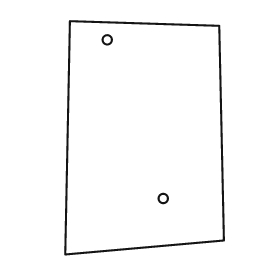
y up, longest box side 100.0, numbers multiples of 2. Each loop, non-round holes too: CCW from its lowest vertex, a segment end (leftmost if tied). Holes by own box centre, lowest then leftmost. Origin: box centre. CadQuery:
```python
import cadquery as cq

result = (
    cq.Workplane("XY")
    .moveTo(-34.0, -50.0)
    .lineTo(34.0, -44.0)
    .lineTo(32.0, 48.0)
    .lineTo(-32.0, 50.0)
    .close()
    .moveTo(8.0, -26.0)
    .circle(2.0)
    .moveTo(-16.0, 42.0)
    .circle(2.0)
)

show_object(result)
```